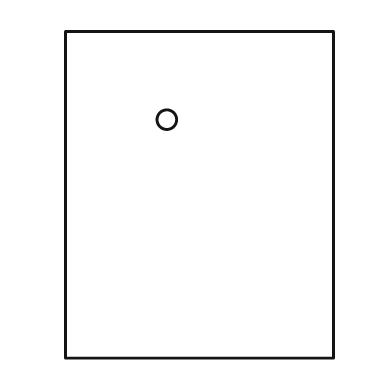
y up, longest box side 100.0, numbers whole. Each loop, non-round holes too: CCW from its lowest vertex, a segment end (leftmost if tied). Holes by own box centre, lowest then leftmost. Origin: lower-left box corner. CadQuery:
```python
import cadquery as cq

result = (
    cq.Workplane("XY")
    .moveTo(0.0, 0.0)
    .lineTo(82.0, 0.0)
    .lineTo(82.0, 100.0)
    .lineTo(0.0, 100.0)
    .close()
    .moveTo(31.0, 73.0)
    .circle(3.0)
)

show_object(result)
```